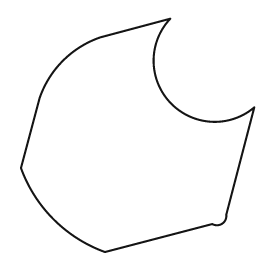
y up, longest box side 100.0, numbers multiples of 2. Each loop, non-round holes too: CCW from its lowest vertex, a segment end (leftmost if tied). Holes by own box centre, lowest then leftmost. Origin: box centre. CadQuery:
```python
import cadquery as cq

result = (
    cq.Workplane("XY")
    .moveTo(-14.0, -50.0)
    .lineTo(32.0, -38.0)
    .threePointArc((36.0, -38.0), (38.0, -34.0))
    .lineTo(50.0, 12.0)
    .threePointArc((14.0, 14.0), (14.0, 50.0))
    .lineTo(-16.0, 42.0)
    .threePointArc((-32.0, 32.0), (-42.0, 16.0))
    .lineTo(-50.0, -14.0)
    .threePointArc((-36.0, -36.0), (-14.0, -50.0))
    .close()
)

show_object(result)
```